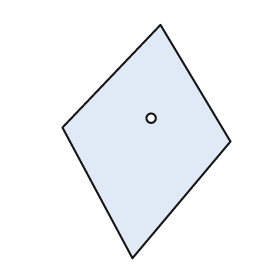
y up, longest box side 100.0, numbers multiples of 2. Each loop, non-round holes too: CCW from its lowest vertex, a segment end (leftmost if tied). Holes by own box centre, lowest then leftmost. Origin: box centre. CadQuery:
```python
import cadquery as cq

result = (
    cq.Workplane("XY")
    .moveTo(-6.0, -50.0)
    .lineTo(36.0, 0.0)
    .lineTo(6.0, 50.0)
    .lineTo(-36.0, 6.0)
    .close()
    .moveTo(2.0, 10.0)
    .circle(2.0)
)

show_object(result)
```